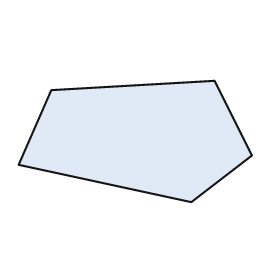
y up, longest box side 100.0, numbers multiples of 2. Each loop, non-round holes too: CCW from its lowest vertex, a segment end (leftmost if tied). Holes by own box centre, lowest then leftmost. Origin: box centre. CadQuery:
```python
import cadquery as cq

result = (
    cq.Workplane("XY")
    .moveTo(24.0, -26.0)
    .lineTo(50.0, -6.0)
    .lineTo(34.0, 26.0)
    .lineTo(-36.0, 22.0)
    .lineTo(-50.0, -10.0)
    .close()
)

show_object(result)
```